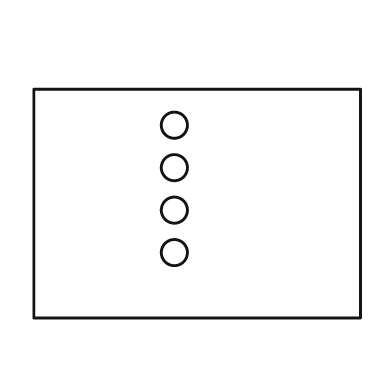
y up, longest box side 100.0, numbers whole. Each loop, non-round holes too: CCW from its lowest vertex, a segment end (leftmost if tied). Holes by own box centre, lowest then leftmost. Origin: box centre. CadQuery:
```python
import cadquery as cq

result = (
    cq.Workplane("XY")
    .moveTo(-50.0, -35.0)
    .lineTo(50.0, -35.0)
    .lineTo(50.0, 35.0)
    .lineTo(-50.0, 35.0)
    .close()
    .moveTo(-7.0, -15.0)
    .circle(4.0)
    .moveTo(-7.0, -2.0)
    .circle(4.0)
    .moveTo(-7.0, 11.0)
    .circle(4.0)
    .moveTo(-7.0, 24.0)
    .circle(4.0)
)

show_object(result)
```